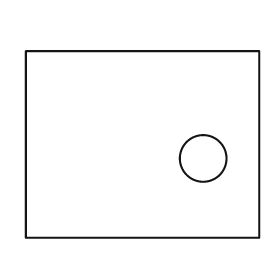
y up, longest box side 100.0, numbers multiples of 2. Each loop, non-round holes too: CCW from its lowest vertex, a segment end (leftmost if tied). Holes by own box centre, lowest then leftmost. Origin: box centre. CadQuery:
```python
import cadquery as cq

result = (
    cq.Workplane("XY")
    .moveTo(-50.0, -40.0)
    .lineTo(50.0, -40.0)
    .lineTo(50.0, 40.0)
    .lineTo(-50.0, 40.0)
    .close()
    .moveTo(26.0, -6.0)
    .circle(10.0)
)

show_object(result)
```